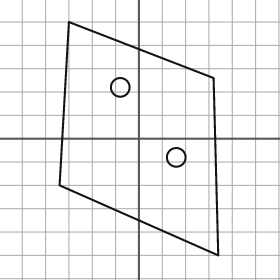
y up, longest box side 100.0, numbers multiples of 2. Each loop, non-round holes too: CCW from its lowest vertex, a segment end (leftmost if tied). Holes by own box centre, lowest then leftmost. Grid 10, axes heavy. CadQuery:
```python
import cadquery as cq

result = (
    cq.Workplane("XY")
    .moveTo(34.0, -50.0)
    .lineTo(32.0, 26.0)
    .lineTo(-30.0, 50.0)
    .lineTo(-34.0, -20.0)
    .close()
    .moveTo(16.0, -8.0)
    .circle(4.0)
    .moveTo(-8.0, 22.0)
    .circle(4.0)
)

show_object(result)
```